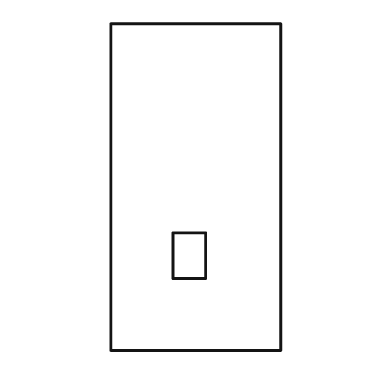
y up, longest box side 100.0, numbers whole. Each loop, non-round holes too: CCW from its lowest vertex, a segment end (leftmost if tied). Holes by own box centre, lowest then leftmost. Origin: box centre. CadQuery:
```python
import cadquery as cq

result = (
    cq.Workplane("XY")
    .moveTo(-26.0, -50.0)
    .lineTo(26.0, -50.0)
    .lineTo(26.0, 50.0)
    .lineTo(-26.0, 50.0)
    .close()
    .moveTo(-7.0, -28.0)
    .lineTo(3.0, -28.0)
    .lineTo(3.0, -14.0)
    .lineTo(-7.0, -14.0)
    .close()
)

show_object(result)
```